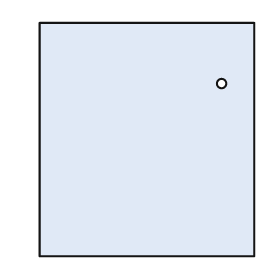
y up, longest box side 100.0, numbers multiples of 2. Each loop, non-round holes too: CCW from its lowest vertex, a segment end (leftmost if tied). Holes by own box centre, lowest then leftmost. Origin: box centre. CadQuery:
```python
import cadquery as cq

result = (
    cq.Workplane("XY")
    .moveTo(-46.0, -50.0)
    .lineTo(46.0, -50.0)
    .lineTo(46.0, 50.0)
    .lineTo(-46.0, 50.0)
    .close()
    .moveTo(32.0, 24.0)
    .circle(2.0)
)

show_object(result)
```